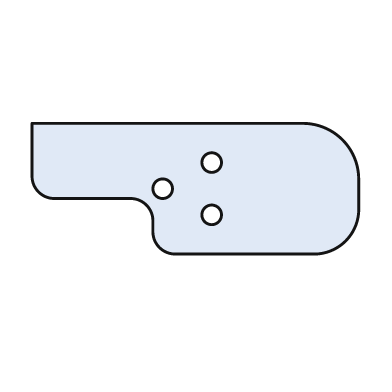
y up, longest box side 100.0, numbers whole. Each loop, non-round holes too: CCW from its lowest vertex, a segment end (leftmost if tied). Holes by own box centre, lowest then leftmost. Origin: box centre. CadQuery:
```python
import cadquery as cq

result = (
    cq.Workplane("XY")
    .moveTo(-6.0, -20.0)
    .lineTo(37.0, -20.0)
    .threePointArc((46.0, -16.0), (50.0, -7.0))
    .lineTo(50.0, 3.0)
    .threePointArc((45.0, 15.0), (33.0, 20.0))
    .lineTo(-50.0, 20.0)
    .lineTo(-50.0, 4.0)
    .threePointArc((-48.0, -1.0), (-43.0, -3.0))
    .lineTo(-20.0, -3.0)
    .threePointArc((-15.0, -5.0), (-13.0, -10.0))
    .lineTo(-13.0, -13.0)
    .threePointArc((-11.0, -18.0), (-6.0, -20.0))
    .close()
    .moveTo(5.0, -8.0)
    .circle(3.0)
    .moveTo(-10.0, 0.0)
    .circle(3.0)
    .moveTo(5.0, 8.0)
    .circle(3.0)
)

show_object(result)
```